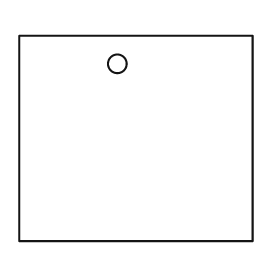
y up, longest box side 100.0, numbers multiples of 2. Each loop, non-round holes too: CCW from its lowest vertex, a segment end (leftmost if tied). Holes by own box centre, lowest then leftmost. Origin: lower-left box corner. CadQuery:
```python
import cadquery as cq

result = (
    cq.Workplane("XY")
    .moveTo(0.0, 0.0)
    .lineTo(100.0, 0.0)
    .lineTo(100.0, 88.0)
    .lineTo(0.0, 88.0)
    .close()
    .moveTo(42.0, 76.0)
    .circle(4.0)
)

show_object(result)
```